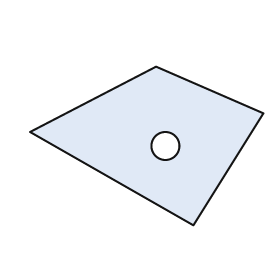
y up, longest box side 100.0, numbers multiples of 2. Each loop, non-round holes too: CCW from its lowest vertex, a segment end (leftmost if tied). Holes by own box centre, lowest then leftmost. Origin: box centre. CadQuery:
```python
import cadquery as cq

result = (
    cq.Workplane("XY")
    .moveTo(20.0, -34.0)
    .lineTo(50.0, 14.0)
    .lineTo(4.0, 34.0)
    .lineTo(-50.0, 6.0)
    .close()
    .moveTo(8.0, 0.0)
    .circle(6.0)
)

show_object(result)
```